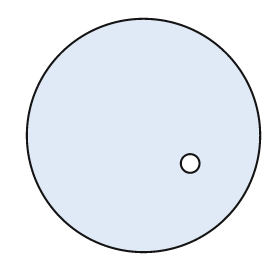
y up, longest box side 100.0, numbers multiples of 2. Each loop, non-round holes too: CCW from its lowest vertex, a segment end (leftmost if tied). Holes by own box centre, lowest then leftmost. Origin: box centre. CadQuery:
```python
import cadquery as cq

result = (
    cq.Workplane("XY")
    .moveTo(0.0, 0.0)
    .circle(50.0)
    .moveTo(20.0, -12.0)
    .circle(4.0)
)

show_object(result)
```